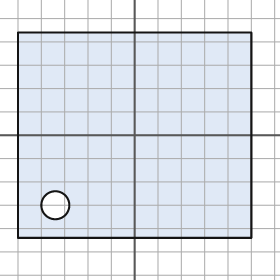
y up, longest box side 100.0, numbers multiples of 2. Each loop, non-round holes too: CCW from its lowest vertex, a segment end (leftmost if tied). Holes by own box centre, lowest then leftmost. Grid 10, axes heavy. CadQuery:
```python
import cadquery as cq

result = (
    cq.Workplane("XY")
    .moveTo(-50.0, -44.0)
    .lineTo(50.0, -44.0)
    .lineTo(50.0, 44.0)
    .lineTo(-50.0, 44.0)
    .close()
    .moveTo(-34.0, -30.0)
    .circle(6.0)
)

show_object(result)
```